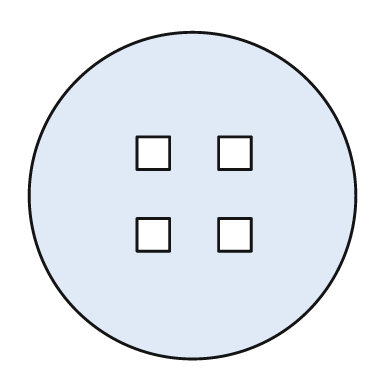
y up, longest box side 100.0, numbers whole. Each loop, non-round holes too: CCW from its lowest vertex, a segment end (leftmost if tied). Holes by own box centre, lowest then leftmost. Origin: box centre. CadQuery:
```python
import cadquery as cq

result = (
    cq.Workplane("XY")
    .moveTo(0.0, 0.0)
    .circle(50.0)
    .moveTo(-17.0, -17.0)
    .lineTo(-7.0, -17.0)
    .lineTo(-7.0, -7.0)
    .lineTo(-17.0, -7.0)
    .close()
    .moveTo(8.0, -17.0)
    .lineTo(18.0, -17.0)
    .lineTo(18.0, -7.0)
    .lineTo(8.0, -7.0)
    .close()
    .moveTo(-17.0, 8.0)
    .lineTo(-7.0, 8.0)
    .lineTo(-7.0, 18.0)
    .lineTo(-17.0, 18.0)
    .close()
    .moveTo(8.0, 8.0)
    .lineTo(18.0, 8.0)
    .lineTo(18.0, 18.0)
    .lineTo(8.0, 18.0)
    .close()
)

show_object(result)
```